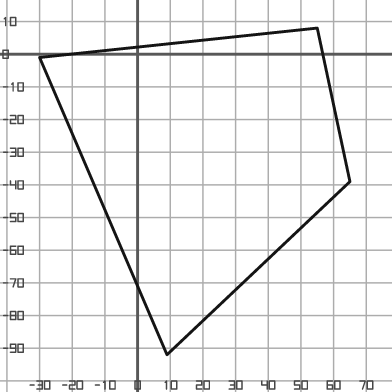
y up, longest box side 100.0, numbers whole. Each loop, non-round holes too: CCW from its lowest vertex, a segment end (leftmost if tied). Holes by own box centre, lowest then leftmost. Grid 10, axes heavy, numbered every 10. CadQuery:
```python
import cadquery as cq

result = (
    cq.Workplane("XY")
    .moveTo(9.0, -92.0)
    .lineTo(65.0, -39.0)
    .lineTo(55.0, 8.0)
    .lineTo(-30.0, -1.0)
    .close()
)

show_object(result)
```